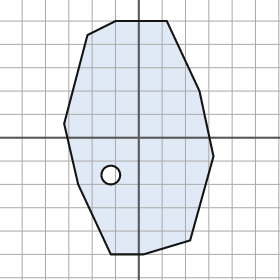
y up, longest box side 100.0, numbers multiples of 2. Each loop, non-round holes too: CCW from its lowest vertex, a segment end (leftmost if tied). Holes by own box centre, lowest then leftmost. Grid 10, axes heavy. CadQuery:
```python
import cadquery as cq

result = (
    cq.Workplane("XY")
    .moveTo(-12.0, -50.0)
    .lineTo(2.0, -50.0)
    .lineTo(22.0, -44.0)
    .lineTo(32.0, -8.0)
    .lineTo(26.0, 20.0)
    .lineTo(12.0, 50.0)
    .lineTo(-10.0, 50.0)
    .lineTo(-22.0, 44.0)
    .lineTo(-32.0, 6.0)
    .lineTo(-26.0, -20.0)
    .close()
    .moveTo(-12.0, -16.0)
    .circle(4.0)
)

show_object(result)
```